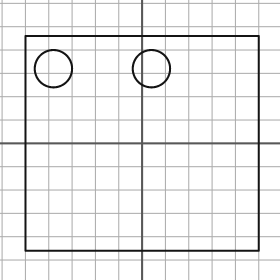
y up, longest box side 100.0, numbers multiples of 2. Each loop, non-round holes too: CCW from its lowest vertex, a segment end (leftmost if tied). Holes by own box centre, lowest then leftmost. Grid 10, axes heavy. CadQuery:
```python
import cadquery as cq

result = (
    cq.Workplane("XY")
    .moveTo(-50.0, -46.0)
    .lineTo(50.0, -46.0)
    .lineTo(50.0, 46.0)
    .lineTo(-50.0, 46.0)
    .close()
    .moveTo(-38.0, 32.0)
    .circle(8.0)
    .moveTo(4.0, 32.0)
    .circle(8.0)
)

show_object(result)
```